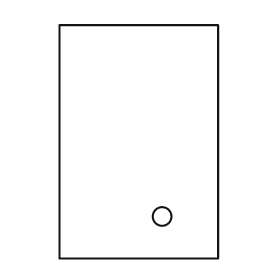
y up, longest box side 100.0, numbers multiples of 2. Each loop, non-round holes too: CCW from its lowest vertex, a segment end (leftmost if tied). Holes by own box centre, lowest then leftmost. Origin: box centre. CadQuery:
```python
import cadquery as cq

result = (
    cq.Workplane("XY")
    .moveTo(-34.0, -50.0)
    .lineTo(34.0, -50.0)
    .lineTo(34.0, 50.0)
    .lineTo(-34.0, 50.0)
    .close()
    .moveTo(10.0, -32.0)
    .circle(4.0)
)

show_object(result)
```